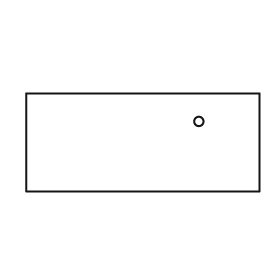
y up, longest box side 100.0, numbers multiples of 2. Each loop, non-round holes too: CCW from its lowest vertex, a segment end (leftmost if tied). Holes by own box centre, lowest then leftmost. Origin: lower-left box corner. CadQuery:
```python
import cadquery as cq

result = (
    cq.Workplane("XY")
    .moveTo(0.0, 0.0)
    .lineTo(100.0, 0.0)
    .lineTo(100.0, 42.0)
    .lineTo(0.0, 42.0)
    .close()
    .moveTo(74.0, 30.0)
    .circle(2.0)
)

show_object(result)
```